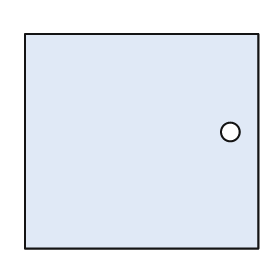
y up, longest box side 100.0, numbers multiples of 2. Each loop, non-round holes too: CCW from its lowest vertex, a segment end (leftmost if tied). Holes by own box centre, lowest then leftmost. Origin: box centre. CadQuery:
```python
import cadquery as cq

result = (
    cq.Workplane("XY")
    .moveTo(-50.0, -46.0)
    .lineTo(50.0, -46.0)
    .lineTo(50.0, 46.0)
    .lineTo(-50.0, 46.0)
    .close()
    .moveTo(38.0, 4.0)
    .circle(4.0)
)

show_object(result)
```